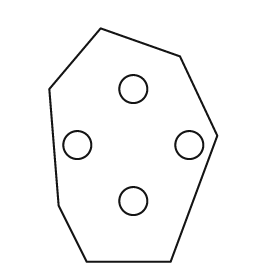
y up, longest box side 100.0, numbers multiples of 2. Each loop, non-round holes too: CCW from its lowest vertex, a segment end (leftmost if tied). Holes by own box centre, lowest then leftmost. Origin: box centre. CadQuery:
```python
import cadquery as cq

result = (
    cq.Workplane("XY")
    .moveTo(-20.0, -50.0)
    .lineTo(16.0, -50.0)
    .lineTo(36.0, 4.0)
    .lineTo(20.0, 38.0)
    .lineTo(-14.0, 50.0)
    .lineTo(-36.0, 24.0)
    .lineTo(-32.0, -26.0)
    .close()
    .moveTo(0.0, -24.0)
    .circle(6.0)
    .moveTo(-24.0, 0.0)
    .circle(6.0)
    .moveTo(24.0, 0.0)
    .circle(6.0)
    .moveTo(0.0, 24.0)
    .circle(6.0)
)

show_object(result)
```